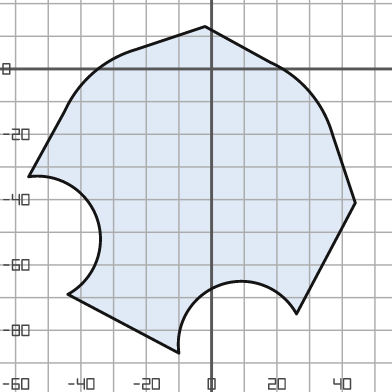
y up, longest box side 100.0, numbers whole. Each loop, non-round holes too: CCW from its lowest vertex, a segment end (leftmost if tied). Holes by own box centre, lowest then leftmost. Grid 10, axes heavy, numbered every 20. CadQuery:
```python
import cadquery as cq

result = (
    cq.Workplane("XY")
    .moveTo(-10.0, -87.0)
    .threePointArc((3.0, -66.0), (26.0, -75.0))
    .lineTo(44.0, -41.0)
    .lineTo(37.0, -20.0)
    .threePointArc((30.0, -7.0), (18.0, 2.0))
    .lineTo(-2.0, 13.0)
    .lineTo(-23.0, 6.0)
    .threePointArc((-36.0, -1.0), (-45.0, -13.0))
    .lineTo(-56.0, -33.0)
    .threePointArc((-35.0, -46.0), (-44.0, -69.0))
    .close()
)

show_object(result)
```